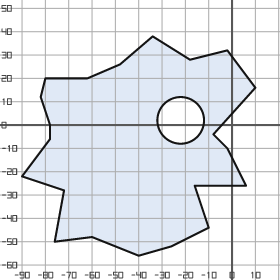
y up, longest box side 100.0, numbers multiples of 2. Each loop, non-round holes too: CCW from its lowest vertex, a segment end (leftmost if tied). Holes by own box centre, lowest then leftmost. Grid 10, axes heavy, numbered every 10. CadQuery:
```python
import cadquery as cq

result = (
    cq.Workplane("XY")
    .moveTo(-40.0, -56.0)
    .lineTo(-26.0, -52.0)
    .lineTo(-10.0, -44.0)
    .lineTo(-16.0, -26.0)
    .lineTo(6.0, -26.0)
    .lineTo(-2.0, -10.0)
    .lineTo(-8.0, -4.0)
    .lineTo(10.0, 16.0)
    .lineTo(-2.0, 32.0)
    .lineTo(-18.0, 28.0)
    .lineTo(-34.0, 38.0)
    .lineTo(-48.0, 26.0)
    .lineTo(-62.0, 20.0)
    .lineTo(-80.0, 20.0)
    .lineTo(-82.0, 12.0)
    .lineTo(-78.0, 0.0)
    .lineTo(-78.0, -6.0)
    .lineTo(-90.0, -22.0)
    .lineTo(-72.0, -28.0)
    .lineTo(-76.0, -50.0)
    .lineTo(-60.0, -48.0)
    .close()
    .moveTo(-22.0, 2.0)
    .circle(10.0)
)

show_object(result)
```